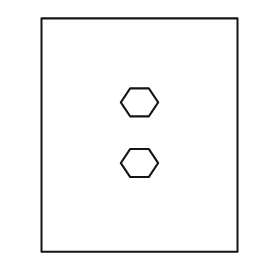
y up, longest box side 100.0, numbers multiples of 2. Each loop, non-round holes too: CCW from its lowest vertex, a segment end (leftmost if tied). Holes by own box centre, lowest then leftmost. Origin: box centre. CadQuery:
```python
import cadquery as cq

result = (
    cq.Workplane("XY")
    .moveTo(-42.0, -50.0)
    .lineTo(42.0, -50.0)
    .lineTo(42.0, 50.0)
    .lineTo(-42.0, 50.0)
    .close()
    .moveTo(-4.0, -18.0)
    .lineTo(4.0, -18.0)
    .lineTo(8.0, -12.0)
    .lineTo(4.0, -6.0)
    .lineTo(-4.0, -6.0)
    .lineTo(-8.0, -12.0)
    .close()
    .moveTo(-4.0, 8.0)
    .lineTo(4.0, 8.0)
    .lineTo(8.0, 14.0)
    .lineTo(4.0, 20.0)
    .lineTo(-4.0, 20.0)
    .lineTo(-8.0, 14.0)
    .close()
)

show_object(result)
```